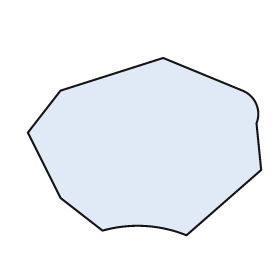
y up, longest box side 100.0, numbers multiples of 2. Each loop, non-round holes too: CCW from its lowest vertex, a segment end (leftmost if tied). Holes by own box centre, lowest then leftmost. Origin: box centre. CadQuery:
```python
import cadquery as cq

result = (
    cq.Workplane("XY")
    .moveTo(18.0, -38.0)
    .lineTo(50.0, -10.0)
    .lineTo(48.0, 10.0)
    .threePointArc((48.0, 18.0), (42.0, 24.0))
    .lineTo(8.0, 38.0)
    .lineTo(-36.0, 24.0)
    .lineTo(-50.0, 6.0)
    .lineTo(-36.0, -22.0)
    .lineTo(-18.0, -36.0)
    .threePointArc((0.0, -34.0), (18.0, -38.0))
    .close()
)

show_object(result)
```